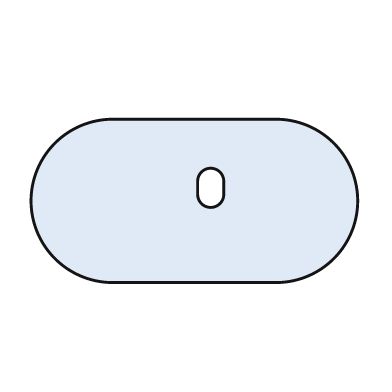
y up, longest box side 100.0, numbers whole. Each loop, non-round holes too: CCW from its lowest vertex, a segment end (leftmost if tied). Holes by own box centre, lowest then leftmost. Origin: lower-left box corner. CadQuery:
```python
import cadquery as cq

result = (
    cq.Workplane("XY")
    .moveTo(25.0, 0.0)
    .lineTo(75.0, 0.0)
    .threePointArc((100.0, 25.0), (75.0, 50.0))
    .lineTo(25.0, 50.0)
    .threePointArc((0.0, 25.0), (25.0, 0.0))
    .close()
    .moveTo(51.0, 27.0)
    .threePointArc((55.0, 23.0), (59.0, 27.0))
    .lineTo(59.0, 31.0)
    .threePointArc((55.0, 35.0), (51.0, 31.0))
    .close()
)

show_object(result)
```